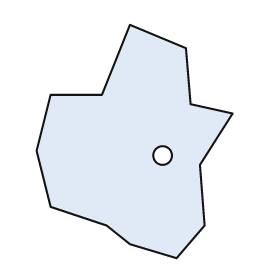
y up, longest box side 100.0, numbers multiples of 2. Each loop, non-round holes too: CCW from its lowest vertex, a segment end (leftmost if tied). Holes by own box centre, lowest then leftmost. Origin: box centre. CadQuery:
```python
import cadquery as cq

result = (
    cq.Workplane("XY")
    .moveTo(18.0, -50.0)
    .lineTo(30.0, -36.0)
    .lineTo(28.0, -10.0)
    .lineTo(42.0, 12.0)
    .lineTo(24.0, 16.0)
    .lineTo(22.0, 40.0)
    .lineTo(-2.0, 50.0)
    .lineTo(-14.0, 20.0)
    .lineTo(-36.0, 20.0)
    .lineTo(-42.0, -4.0)
    .lineTo(-36.0, -28.0)
    .lineTo(-12.0, -36.0)
    .lineTo(-2.0, -44.0)
    .close()
    .moveTo(12.0, -6.0)
    .circle(4.0)
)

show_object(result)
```